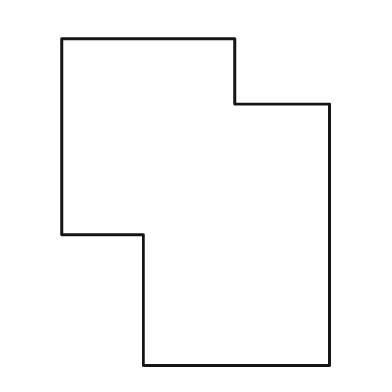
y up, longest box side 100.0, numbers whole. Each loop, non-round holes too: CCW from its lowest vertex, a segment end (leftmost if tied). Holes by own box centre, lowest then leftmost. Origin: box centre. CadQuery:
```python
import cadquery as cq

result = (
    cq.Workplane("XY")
    .moveTo(-16.0, -50.0)
    .lineTo(41.0, -50.0)
    .lineTo(41.0, 30.0)
    .lineTo(12.0, 30.0)
    .lineTo(12.0, 50.0)
    .lineTo(-41.0, 50.0)
    .lineTo(-41.0, -10.0)
    .lineTo(-16.0, -10.0)
    .close()
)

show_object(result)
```